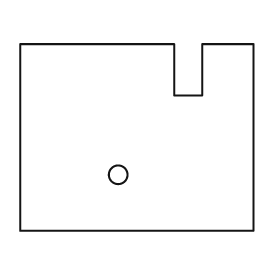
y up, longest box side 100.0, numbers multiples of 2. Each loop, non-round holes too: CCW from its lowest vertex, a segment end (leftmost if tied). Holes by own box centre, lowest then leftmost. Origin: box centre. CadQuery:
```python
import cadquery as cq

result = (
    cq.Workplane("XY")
    .moveTo(-50.0, -40.0)
    .lineTo(50.0, -40.0)
    .lineTo(50.0, 40.0)
    .lineTo(28.0, 40.0)
    .lineTo(28.0, 18.0)
    .lineTo(16.0, 18.0)
    .lineTo(16.0, 40.0)
    .lineTo(-50.0, 40.0)
    .close()
    .moveTo(-8.0, -16.0)
    .circle(4.0)
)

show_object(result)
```